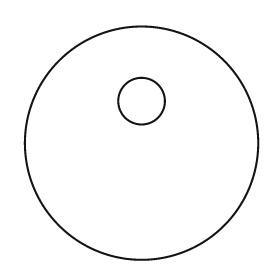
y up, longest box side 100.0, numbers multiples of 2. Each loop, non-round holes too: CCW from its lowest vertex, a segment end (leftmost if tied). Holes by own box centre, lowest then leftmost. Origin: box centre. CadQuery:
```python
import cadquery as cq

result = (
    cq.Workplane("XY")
    .moveTo(0.0, 0.0)
    .circle(50.0)
    .moveTo(0.0, 18.0)
    .circle(10.0)
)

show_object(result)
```